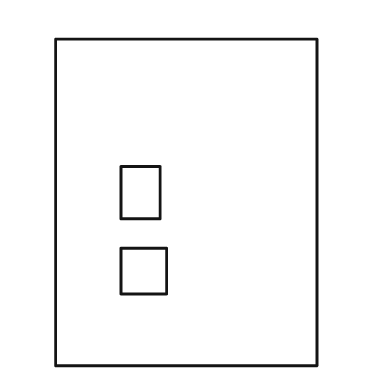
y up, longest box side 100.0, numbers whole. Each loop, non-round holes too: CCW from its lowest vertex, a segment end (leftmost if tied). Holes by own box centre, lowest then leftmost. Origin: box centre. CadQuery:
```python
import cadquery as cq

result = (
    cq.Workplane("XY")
    .moveTo(-40.0, -50.0)
    .lineTo(40.0, -50.0)
    .lineTo(40.0, 50.0)
    .lineTo(-40.0, 50.0)
    .close()
    .moveTo(-20.0, -28.0)
    .lineTo(-6.0, -28.0)
    .lineTo(-6.0, -14.0)
    .lineTo(-20.0, -14.0)
    .close()
    .moveTo(-20.0, -5.0)
    .lineTo(-8.0, -5.0)
    .lineTo(-8.0, 11.0)
    .lineTo(-20.0, 11.0)
    .close()
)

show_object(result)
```